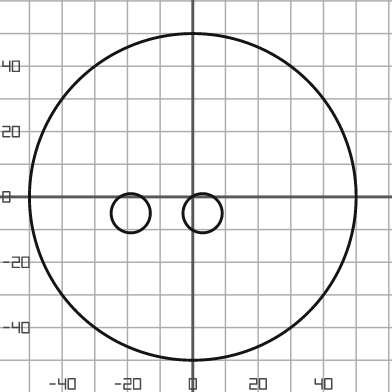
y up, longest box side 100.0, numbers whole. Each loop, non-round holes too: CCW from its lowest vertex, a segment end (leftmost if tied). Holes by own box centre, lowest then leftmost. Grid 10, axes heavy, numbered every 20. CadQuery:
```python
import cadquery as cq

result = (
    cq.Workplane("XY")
    .moveTo(0.0, 0.0)
    .circle(50.0)
    .moveTo(-19.0, -5.0)
    .circle(6.0)
    .moveTo(3.0, -5.0)
    .circle(6.0)
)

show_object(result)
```